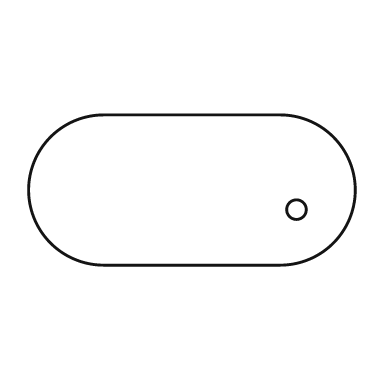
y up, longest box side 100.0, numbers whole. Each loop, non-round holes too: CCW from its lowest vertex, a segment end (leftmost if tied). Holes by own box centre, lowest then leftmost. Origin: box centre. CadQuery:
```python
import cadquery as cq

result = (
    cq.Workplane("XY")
    .moveTo(-27.0, -23.0)
    .lineTo(27.0, -23.0)
    .threePointArc((50.0, 0.0), (27.0, 23.0))
    .lineTo(-27.0, 23.0)
    .threePointArc((-50.0, 0.0), (-27.0, -23.0))
    .close()
    .moveTo(32.0, -6.0)
    .circle(3.0)
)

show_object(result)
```